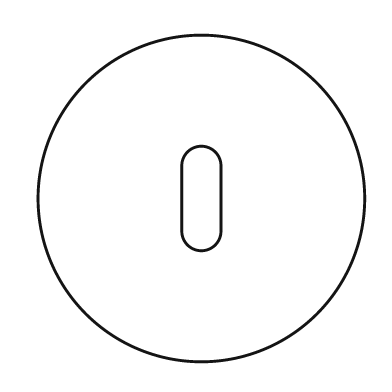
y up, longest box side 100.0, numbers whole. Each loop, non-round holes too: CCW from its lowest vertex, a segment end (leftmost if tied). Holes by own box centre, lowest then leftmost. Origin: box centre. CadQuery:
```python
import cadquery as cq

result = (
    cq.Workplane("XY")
    .moveTo(0.0, 0.0)
    .circle(50.0)
    .moveTo(-6.0, -10.0)
    .threePointArc((0.0, -16.0), (6.0, -10.0))
    .lineTo(6.0, 10.0)
    .threePointArc((0.0, 16.0), (-6.0, 10.0))
    .close()
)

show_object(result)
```